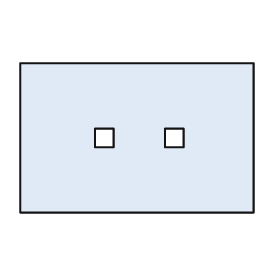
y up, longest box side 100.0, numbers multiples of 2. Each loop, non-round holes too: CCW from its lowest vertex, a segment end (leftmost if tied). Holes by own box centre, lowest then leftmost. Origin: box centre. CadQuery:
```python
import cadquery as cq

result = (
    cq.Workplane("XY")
    .moveTo(-50.0, -32.0)
    .lineTo(50.0, -32.0)
    .lineTo(50.0, 32.0)
    .lineTo(-50.0, 32.0)
    .close()
    .moveTo(-18.0, -4.0)
    .lineTo(-10.0, -4.0)
    .lineTo(-10.0, 4.0)
    .lineTo(-18.0, 4.0)
    .close()
    .moveTo(12.0, -4.0)
    .lineTo(20.0, -4.0)
    .lineTo(20.0, 4.0)
    .lineTo(12.0, 4.0)
    .close()
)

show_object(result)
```